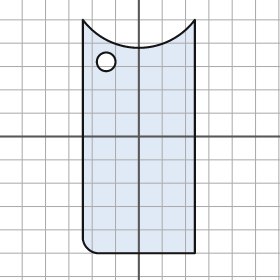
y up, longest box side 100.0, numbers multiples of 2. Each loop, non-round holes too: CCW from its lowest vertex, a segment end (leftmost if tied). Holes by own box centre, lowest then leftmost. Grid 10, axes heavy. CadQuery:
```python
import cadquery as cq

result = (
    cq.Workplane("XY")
    .moveTo(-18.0, -50.0)
    .lineTo(24.0, -50.0)
    .lineTo(24.0, 50.0)
    .threePointArc((0.0, 38.0), (-24.0, 50.0))
    .lineTo(-24.0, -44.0)
    .threePointArc((-22.0, -48.0), (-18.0, -50.0))
    .close()
    .moveTo(-14.0, 32.0)
    .circle(4.0)
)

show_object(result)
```